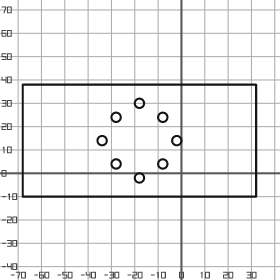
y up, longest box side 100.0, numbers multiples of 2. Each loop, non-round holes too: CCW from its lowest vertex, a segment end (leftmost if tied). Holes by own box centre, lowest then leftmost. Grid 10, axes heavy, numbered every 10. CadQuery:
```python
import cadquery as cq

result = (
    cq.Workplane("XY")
    .moveTo(-68.0, -10.0)
    .lineTo(32.0, -10.0)
    .lineTo(32.0, 38.0)
    .lineTo(-68.0, 38.0)
    .close()
    .moveTo(-18.0, -2.0)
    .circle(2.0)
    .moveTo(-28.0, 4.0)
    .circle(2.0)
    .moveTo(-8.0, 4.0)
    .circle(2.0)
    .moveTo(-34.0, 14.0)
    .circle(2.0)
    .moveTo(-2.0, 14.0)
    .circle(2.0)
    .moveTo(-28.0, 24.0)
    .circle(2.0)
    .moveTo(-8.0, 24.0)
    .circle(2.0)
    .moveTo(-18.0, 30.0)
    .circle(2.0)
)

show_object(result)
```